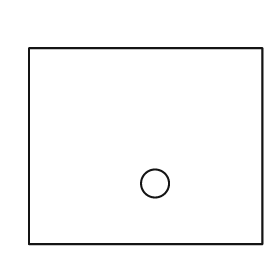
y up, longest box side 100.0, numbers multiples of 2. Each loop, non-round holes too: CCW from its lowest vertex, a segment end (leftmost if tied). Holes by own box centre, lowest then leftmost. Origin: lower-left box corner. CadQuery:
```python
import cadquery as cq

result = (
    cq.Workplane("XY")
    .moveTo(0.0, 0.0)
    .lineTo(100.0, 0.0)
    .lineTo(100.0, 84.0)
    .lineTo(0.0, 84.0)
    .close()
    .moveTo(54.0, 26.0)
    .circle(6.0)
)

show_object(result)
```